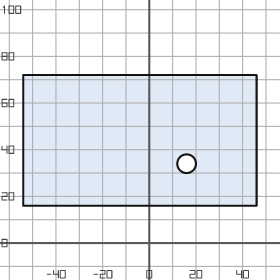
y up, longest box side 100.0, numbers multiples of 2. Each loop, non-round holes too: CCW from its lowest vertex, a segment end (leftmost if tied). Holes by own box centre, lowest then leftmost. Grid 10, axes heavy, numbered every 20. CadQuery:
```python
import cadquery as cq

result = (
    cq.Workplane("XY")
    .moveTo(-54.0, 16.0)
    .lineTo(46.0, 16.0)
    .lineTo(46.0, 72.0)
    .lineTo(-54.0, 72.0)
    .close()
    .moveTo(16.0, 34.0)
    .circle(4.0)
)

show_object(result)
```